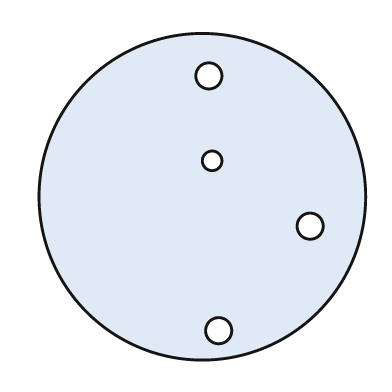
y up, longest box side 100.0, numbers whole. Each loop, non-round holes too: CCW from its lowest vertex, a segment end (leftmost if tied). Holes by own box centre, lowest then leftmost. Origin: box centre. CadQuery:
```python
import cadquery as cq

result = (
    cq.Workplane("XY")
    .moveTo(0.0, 0.0)
    .circle(50.0)
    .moveTo(5.0, -41.0)
    .circle(4.0)
    .moveTo(33.0, -9.0)
    .circle(4.0)
    .moveTo(3.0, 11.0)
    .circle(3.0)
    .moveTo(2.0, 37.0)
    .circle(4.0)
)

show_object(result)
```